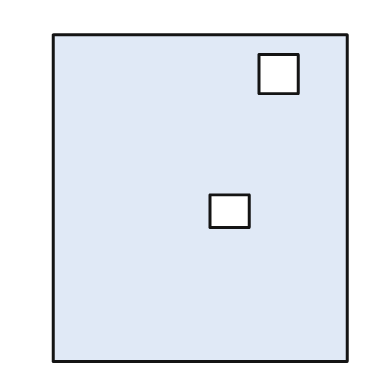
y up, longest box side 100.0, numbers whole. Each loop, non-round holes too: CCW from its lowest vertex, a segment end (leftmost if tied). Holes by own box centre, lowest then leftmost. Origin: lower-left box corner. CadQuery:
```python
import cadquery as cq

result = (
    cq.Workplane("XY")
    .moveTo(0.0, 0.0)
    .lineTo(90.0, 0.0)
    .lineTo(90.0, 100.0)
    .lineTo(0.0, 100.0)
    .close()
    .moveTo(48.0, 41.0)
    .lineTo(60.0, 41.0)
    .lineTo(60.0, 51.0)
    .lineTo(48.0, 51.0)
    .close()
    .moveTo(63.0, 82.0)
    .lineTo(75.0, 82.0)
    .lineTo(75.0, 94.0)
    .lineTo(63.0, 94.0)
    .close()
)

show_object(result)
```